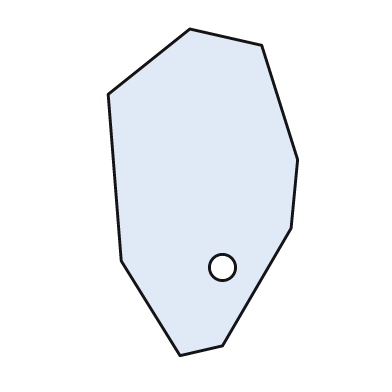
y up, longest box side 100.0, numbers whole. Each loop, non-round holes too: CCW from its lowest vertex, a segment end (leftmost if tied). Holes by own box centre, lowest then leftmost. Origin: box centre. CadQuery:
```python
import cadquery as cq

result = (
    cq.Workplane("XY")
    .moveTo(-7.0, -50.0)
    .lineTo(6.0, -47.0)
    .lineTo(27.0, -11.0)
    .lineTo(29.0, 10.0)
    .lineTo(18.0, 45.0)
    .lineTo(-4.0, 50.0)
    .lineTo(-29.0, 30.0)
    .lineTo(-25.0, -21.0)
    .close()
    .moveTo(6.0, -23.0)
    .circle(4.0)
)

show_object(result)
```